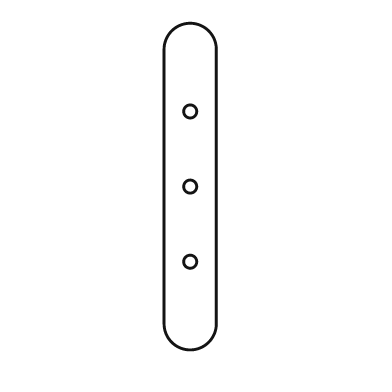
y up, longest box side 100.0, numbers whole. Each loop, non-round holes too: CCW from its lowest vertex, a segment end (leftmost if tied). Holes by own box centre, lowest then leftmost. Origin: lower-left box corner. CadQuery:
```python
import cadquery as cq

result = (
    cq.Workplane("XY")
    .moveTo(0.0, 8.0)
    .threePointArc((8.0, 0.0), (16.0, 8.0))
    .lineTo(16.0, 92.0)
    .threePointArc((8.0, 100.0), (0.0, 92.0))
    .close()
    .moveTo(8.0, 27.0)
    .circle(2.0)
    .moveTo(8.0, 50.0)
    .circle(2.0)
    .moveTo(8.0, 73.0)
    .circle(2.0)
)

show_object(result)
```